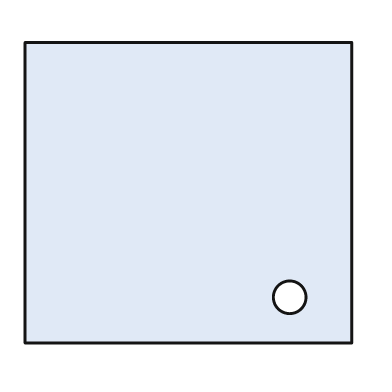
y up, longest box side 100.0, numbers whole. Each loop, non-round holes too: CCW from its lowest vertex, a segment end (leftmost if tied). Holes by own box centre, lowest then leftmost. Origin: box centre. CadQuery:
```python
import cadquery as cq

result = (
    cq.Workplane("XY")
    .moveTo(-50.0, -46.0)
    .lineTo(50.0, -46.0)
    .lineTo(50.0, 46.0)
    .lineTo(-50.0, 46.0)
    .close()
    .moveTo(31.0, -32.0)
    .circle(5.0)
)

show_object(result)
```